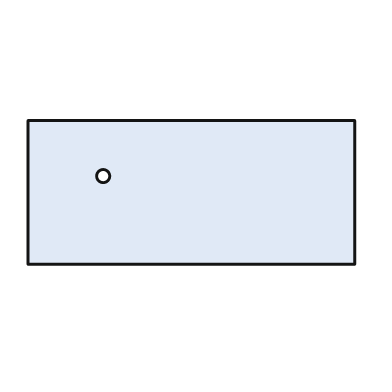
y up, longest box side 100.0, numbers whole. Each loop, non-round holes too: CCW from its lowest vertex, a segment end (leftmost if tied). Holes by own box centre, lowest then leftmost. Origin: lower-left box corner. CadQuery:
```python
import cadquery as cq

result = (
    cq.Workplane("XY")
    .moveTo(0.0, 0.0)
    .lineTo(100.0, 0.0)
    .lineTo(100.0, 44.0)
    .lineTo(0.0, 44.0)
    .close()
    .moveTo(23.0, 27.0)
    .circle(2.0)
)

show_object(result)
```